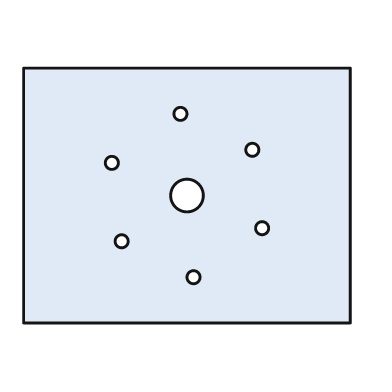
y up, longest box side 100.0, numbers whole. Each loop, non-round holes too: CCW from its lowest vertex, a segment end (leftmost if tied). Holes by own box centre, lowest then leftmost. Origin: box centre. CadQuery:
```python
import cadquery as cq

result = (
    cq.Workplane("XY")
    .moveTo(-50.0, -39.0)
    .lineTo(50.0, -39.0)
    .lineTo(50.0, 39.0)
    .lineTo(-50.0, 39.0)
    .close()
    .moveTo(2.0, -25.0)
    .circle(2.0)
    .moveTo(-20.0, -14.0)
    .circle(2.0)
    .moveTo(23.0, -10.0)
    .circle(2.0)
    .moveTo(0.0, 0.0)
    .circle(5.0)
    .moveTo(-23.0, 10.0)
    .circle(2.0)
    .moveTo(20.0, 14.0)
    .circle(2.0)
    .moveTo(-2.0, 25.0)
    .circle(2.0)
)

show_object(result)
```